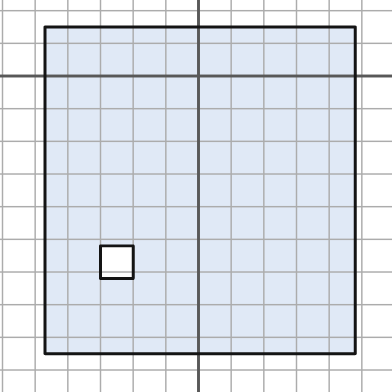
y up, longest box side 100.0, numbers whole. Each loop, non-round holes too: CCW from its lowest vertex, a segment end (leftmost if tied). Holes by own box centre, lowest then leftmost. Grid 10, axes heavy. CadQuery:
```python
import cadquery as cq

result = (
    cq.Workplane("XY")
    .moveTo(-47.0, -85.0)
    .lineTo(48.0, -85.0)
    .lineTo(48.0, 15.0)
    .lineTo(-47.0, 15.0)
    .close()
    .moveTo(-30.0, -62.0)
    .lineTo(-20.0, -62.0)
    .lineTo(-20.0, -52.0)
    .lineTo(-30.0, -52.0)
    .close()
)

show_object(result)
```